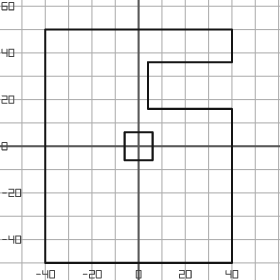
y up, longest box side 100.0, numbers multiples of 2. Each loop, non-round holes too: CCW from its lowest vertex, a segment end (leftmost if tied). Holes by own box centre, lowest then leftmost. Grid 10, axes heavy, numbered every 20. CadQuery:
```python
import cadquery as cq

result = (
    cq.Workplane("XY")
    .moveTo(-40.0, -50.0)
    .lineTo(40.0, -50.0)
    .lineTo(40.0, 16.0)
    .lineTo(4.0, 16.0)
    .lineTo(4.0, 36.0)
    .lineTo(40.0, 36.0)
    .lineTo(40.0, 50.0)
    .lineTo(-40.0, 50.0)
    .close()
    .moveTo(-6.0, -6.0)
    .lineTo(6.0, -6.0)
    .lineTo(6.0, 6.0)
    .lineTo(-6.0, 6.0)
    .close()
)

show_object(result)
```